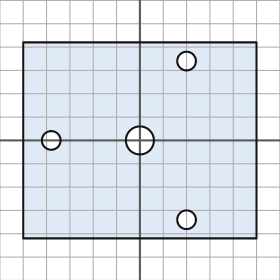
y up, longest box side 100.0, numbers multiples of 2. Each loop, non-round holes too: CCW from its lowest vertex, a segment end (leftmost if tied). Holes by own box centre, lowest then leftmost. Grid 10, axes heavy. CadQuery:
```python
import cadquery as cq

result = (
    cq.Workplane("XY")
    .moveTo(-50.0, -42.0)
    .lineTo(50.0, -42.0)
    .lineTo(50.0, 42.0)
    .lineTo(-50.0, 42.0)
    .close()
    .moveTo(20.0, -34.0)
    .circle(4.0)
    .moveTo(-38.0, 0.0)
    .circle(4.0)
    .moveTo(0.0, 0.0)
    .circle(6.0)
    .moveTo(20.0, 34.0)
    .circle(4.0)
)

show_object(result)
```